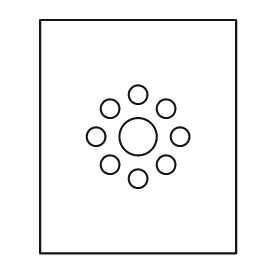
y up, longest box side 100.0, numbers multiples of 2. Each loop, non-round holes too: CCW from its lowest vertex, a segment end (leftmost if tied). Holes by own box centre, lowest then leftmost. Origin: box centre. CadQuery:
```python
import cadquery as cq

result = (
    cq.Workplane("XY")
    .moveTo(-42.0, -50.0)
    .lineTo(42.0, -50.0)
    .lineTo(42.0, 50.0)
    .lineTo(-42.0, 50.0)
    .close()
    .moveTo(0.0, -18.0)
    .circle(4.0)
    .moveTo(-12.0, -12.0)
    .circle(4.0)
    .moveTo(12.0, -12.0)
    .circle(4.0)
    .moveTo(-18.0, 0.0)
    .circle(4.0)
    .moveTo(0.0, 0.0)
    .circle(8.0)
    .moveTo(18.0, 0.0)
    .circle(4.0)
    .moveTo(-12.0, 12.0)
    .circle(4.0)
    .moveTo(12.0, 12.0)
    .circle(4.0)
    .moveTo(0.0, 18.0)
    .circle(4.0)
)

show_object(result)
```